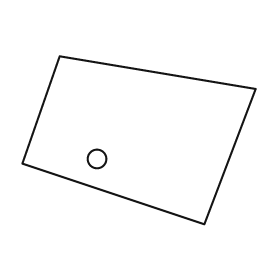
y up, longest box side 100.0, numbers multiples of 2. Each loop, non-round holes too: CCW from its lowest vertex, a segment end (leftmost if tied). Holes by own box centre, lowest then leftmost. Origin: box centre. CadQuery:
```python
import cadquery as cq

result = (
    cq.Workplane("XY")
    .moveTo(28.0, -36.0)
    .lineTo(50.0, 22.0)
    .lineTo(-34.0, 36.0)
    .lineTo(-50.0, -10.0)
    .close()
    .moveTo(-18.0, -8.0)
    .circle(4.0)
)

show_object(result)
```